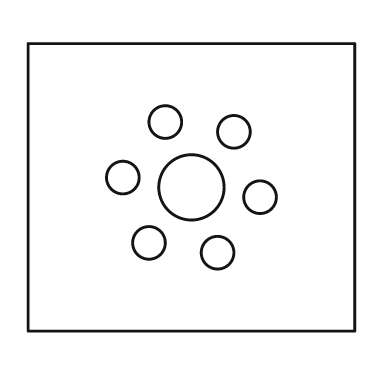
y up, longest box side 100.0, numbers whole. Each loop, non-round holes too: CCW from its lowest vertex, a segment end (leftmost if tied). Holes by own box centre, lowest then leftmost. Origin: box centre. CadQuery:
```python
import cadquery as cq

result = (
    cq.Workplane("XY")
    .moveTo(-50.0, -44.0)
    .lineTo(50.0, -44.0)
    .lineTo(50.0, 44.0)
    .lineTo(-50.0, 44.0)
    .close()
    .moveTo(8.0, -20.0)
    .circle(5.0)
    .moveTo(-13.0, -17.0)
    .circle(5.0)
    .moveTo(21.0, -3.0)
    .circle(5.0)
    .moveTo(0.0, 0.0)
    .circle(10.0)
    .moveTo(-21.0, 3.0)
    .circle(5.0)
    .moveTo(13.0, 17.0)
    .circle(5.0)
    .moveTo(-8.0, 20.0)
    .circle(5.0)
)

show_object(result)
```